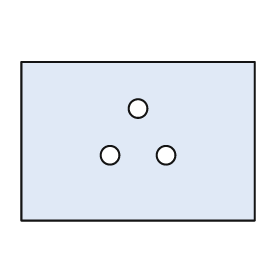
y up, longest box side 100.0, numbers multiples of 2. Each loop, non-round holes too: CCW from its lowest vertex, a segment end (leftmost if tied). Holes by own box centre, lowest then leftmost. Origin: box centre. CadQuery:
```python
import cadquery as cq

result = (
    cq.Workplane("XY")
    .moveTo(-50.0, -34.0)
    .lineTo(50.0, -34.0)
    .lineTo(50.0, 34.0)
    .lineTo(-50.0, 34.0)
    .close()
    .moveTo(-12.0, -6.0)
    .circle(4.0)
    .moveTo(12.0, -6.0)
    .circle(4.0)
    .moveTo(0.0, 14.0)
    .circle(4.0)
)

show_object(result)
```